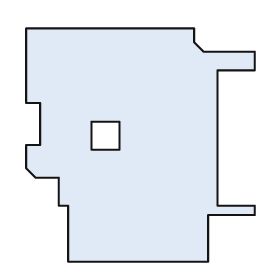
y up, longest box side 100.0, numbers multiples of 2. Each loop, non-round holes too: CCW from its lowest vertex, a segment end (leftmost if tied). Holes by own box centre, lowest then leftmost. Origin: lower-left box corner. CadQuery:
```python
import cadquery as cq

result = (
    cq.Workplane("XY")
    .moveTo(18.0, 0.0)
    .lineTo(78.0, 0.0)
    .lineTo(78.0, 20.0)
    .lineTo(98.0, 20.0)
    .lineTo(98.0, 24.0)
    .lineTo(82.0, 24.0)
    .lineTo(82.0, 82.0)
    .lineTo(98.0, 82.0)
    .lineTo(98.0, 90.0)
    .lineTo(76.0, 90.0)
    .lineTo(72.0, 94.0)
    .lineTo(72.0, 100.0)
    .lineTo(0.0, 100.0)
    .lineTo(0.0, 68.0)
    .lineTo(6.0, 68.0)
    .lineTo(6.0, 50.0)
    .lineTo(0.0, 50.0)
    .lineTo(0.0, 40.0)
    .lineTo(4.0, 36.0)
    .lineTo(14.0, 36.0)
    .lineTo(14.0, 24.0)
    .lineTo(18.0, 24.0)
    .close()
    .moveTo(28.0, 48.0)
    .lineTo(40.0, 48.0)
    .lineTo(40.0, 60.0)
    .lineTo(28.0, 60.0)
    .close()
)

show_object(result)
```